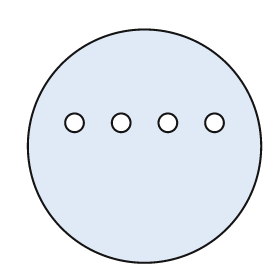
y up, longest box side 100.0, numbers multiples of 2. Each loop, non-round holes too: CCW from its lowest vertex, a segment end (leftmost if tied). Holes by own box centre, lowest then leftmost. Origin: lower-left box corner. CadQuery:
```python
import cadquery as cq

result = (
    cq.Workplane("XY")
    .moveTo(50.0, 50.0)
    .circle(50.0)
    .moveTo(20.0, 60.0)
    .circle(4.0)
    .moveTo(40.0, 60.0)
    .circle(4.0)
    .moveTo(60.0, 60.0)
    .circle(4.0)
    .moveTo(80.0, 60.0)
    .circle(4.0)
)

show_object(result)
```